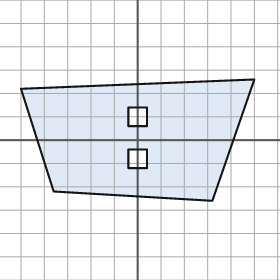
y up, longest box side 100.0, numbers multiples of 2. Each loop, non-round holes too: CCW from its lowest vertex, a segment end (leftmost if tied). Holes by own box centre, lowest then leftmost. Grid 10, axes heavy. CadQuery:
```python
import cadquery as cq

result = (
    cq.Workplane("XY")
    .moveTo(32.0, -26.0)
    .lineTo(50.0, 26.0)
    .lineTo(-50.0, 22.0)
    .lineTo(-36.0, -22.0)
    .close()
    .moveTo(-4.0, -12.0)
    .lineTo(4.0, -12.0)
    .lineTo(4.0, -4.0)
    .lineTo(-4.0, -4.0)
    .close()
    .moveTo(-4.0, 6.0)
    .lineTo(4.0, 6.0)
    .lineTo(4.0, 14.0)
    .lineTo(-4.0, 14.0)
    .close()
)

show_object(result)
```